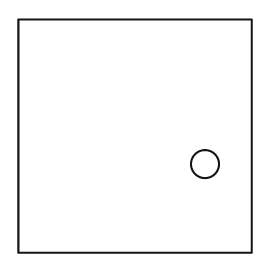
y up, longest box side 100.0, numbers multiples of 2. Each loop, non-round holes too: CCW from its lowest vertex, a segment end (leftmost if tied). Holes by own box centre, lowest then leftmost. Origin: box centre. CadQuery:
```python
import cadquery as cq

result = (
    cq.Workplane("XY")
    .moveTo(-50.0, -50.0)
    .lineTo(50.0, -50.0)
    .lineTo(50.0, 50.0)
    .lineTo(-50.0, 50.0)
    .close()
    .moveTo(30.0, -12.0)
    .circle(6.0)
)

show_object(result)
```